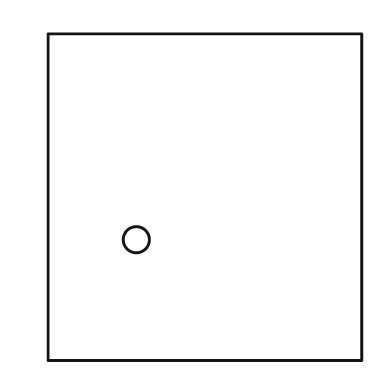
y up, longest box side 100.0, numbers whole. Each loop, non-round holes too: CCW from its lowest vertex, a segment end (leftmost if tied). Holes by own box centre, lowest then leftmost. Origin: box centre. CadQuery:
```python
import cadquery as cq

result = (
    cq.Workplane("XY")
    .moveTo(-48.0, -50.0)
    .lineTo(48.0, -50.0)
    .lineTo(48.0, 50.0)
    .lineTo(-48.0, 50.0)
    .close()
    .moveTo(-21.0, -13.0)
    .circle(4.0)
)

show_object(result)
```